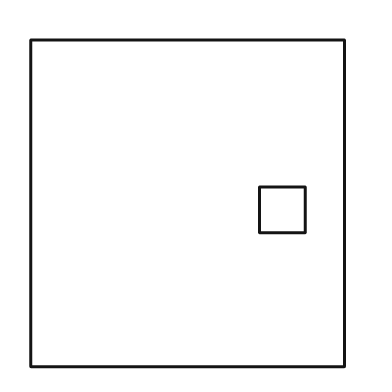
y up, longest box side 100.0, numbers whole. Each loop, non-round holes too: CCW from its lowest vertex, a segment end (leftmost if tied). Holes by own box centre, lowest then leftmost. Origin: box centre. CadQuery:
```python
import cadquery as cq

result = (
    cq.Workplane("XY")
    .moveTo(-48.0, -50.0)
    .lineTo(48.0, -50.0)
    .lineTo(48.0, 50.0)
    .lineTo(-48.0, 50.0)
    .close()
    .moveTo(22.0, -9.0)
    .lineTo(36.0, -9.0)
    .lineTo(36.0, 5.0)
    .lineTo(22.0, 5.0)
    .close()
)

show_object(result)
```